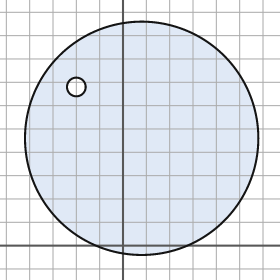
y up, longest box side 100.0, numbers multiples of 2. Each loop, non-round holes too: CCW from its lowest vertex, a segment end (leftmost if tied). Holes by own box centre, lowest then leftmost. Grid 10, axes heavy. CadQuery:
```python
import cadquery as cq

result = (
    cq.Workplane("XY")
    .moveTo(8.0, 46.0)
    .circle(50.0)
    .moveTo(-20.0, 68.0)
    .circle(4.0)
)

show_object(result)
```